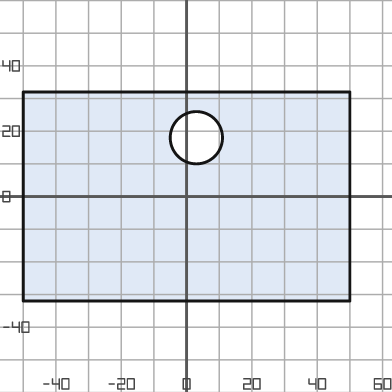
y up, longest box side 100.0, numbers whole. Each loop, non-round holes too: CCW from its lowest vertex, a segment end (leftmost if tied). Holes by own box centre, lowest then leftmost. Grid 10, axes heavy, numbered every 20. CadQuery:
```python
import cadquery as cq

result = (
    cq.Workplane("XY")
    .moveTo(-50.0, -32.0)
    .lineTo(50.0, -32.0)
    .lineTo(50.0, 32.0)
    .lineTo(-50.0, 32.0)
    .close()
    .moveTo(3.0, 18.0)
    .circle(8.0)
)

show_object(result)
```